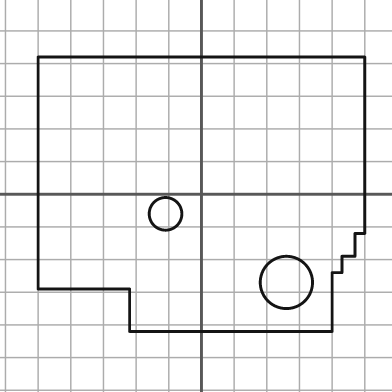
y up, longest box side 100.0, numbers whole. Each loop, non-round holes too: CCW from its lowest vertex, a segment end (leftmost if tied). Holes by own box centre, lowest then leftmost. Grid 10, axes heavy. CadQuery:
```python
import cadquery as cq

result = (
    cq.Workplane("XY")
    .moveTo(-22.0, -42.0)
    .lineTo(40.0, -42.0)
    .lineTo(40.0, -24.0)
    .lineTo(43.0, -24.0)
    .lineTo(43.0, -19.0)
    .lineTo(47.0, -19.0)
    .lineTo(47.0, -12.0)
    .lineTo(50.0, -12.0)
    .lineTo(50.0, 42.0)
    .lineTo(-50.0, 42.0)
    .lineTo(-50.0, -29.0)
    .lineTo(-22.0, -29.0)
    .close()
    .moveTo(26.0, -27.0)
    .circle(8.0)
    .moveTo(-11.0, -6.0)
    .circle(5.0)
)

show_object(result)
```